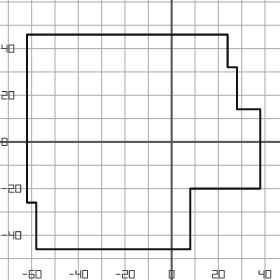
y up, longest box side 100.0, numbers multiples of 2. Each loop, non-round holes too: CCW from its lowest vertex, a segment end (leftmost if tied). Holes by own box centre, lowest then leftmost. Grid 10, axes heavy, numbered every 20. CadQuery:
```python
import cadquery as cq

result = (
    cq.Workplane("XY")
    .moveTo(-58.0, -46.0)
    .lineTo(8.0, -46.0)
    .lineTo(8.0, -20.0)
    .lineTo(38.0, -20.0)
    .lineTo(38.0, 14.0)
    .lineTo(28.0, 14.0)
    .lineTo(28.0, 32.0)
    .lineTo(24.0, 32.0)
    .lineTo(24.0, 46.0)
    .lineTo(-62.0, 46.0)
    .lineTo(-62.0, -26.0)
    .lineTo(-58.0, -26.0)
    .close()
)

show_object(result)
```